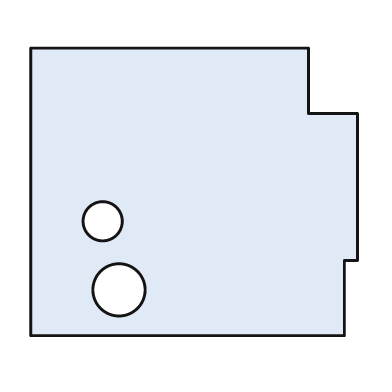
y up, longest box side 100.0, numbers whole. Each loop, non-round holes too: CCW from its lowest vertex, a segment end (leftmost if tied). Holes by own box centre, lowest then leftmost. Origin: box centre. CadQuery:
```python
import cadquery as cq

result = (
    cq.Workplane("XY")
    .moveTo(-50.0, -44.0)
    .lineTo(46.0, -44.0)
    .lineTo(46.0, -21.0)
    .lineTo(50.0, -21.0)
    .lineTo(50.0, 24.0)
    .lineTo(35.0, 24.0)
    .lineTo(35.0, 44.0)
    .lineTo(-50.0, 44.0)
    .close()
    .moveTo(-23.0, -30.0)
    .circle(8.0)
    .moveTo(-28.0, -9.0)
    .circle(6.0)
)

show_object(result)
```